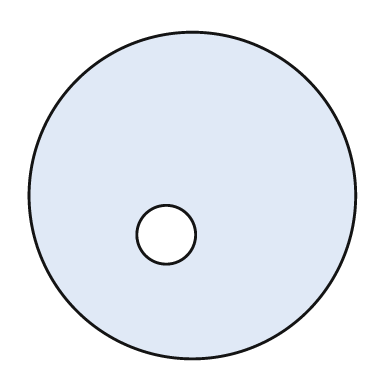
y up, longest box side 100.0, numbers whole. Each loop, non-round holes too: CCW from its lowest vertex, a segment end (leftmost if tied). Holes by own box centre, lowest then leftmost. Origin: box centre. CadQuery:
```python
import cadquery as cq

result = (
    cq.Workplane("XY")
    .moveTo(0.0, 0.0)
    .circle(50.0)
    .moveTo(-8.0, -12.0)
    .circle(9.0)
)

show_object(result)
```